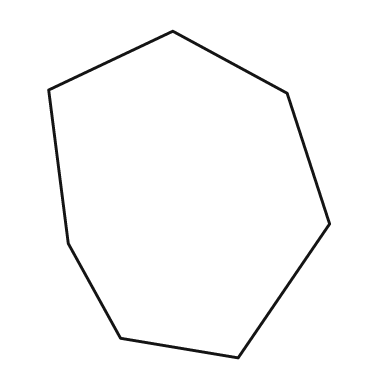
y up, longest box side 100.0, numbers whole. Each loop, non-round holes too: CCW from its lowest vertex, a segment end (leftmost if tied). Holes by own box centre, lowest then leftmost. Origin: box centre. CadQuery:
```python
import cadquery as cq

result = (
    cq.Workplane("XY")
    .moveTo(15.0, -50.0)
    .lineTo(43.0, -9.0)
    .lineTo(30.0, 31.0)
    .lineTo(-5.0, 50.0)
    .lineTo(-43.0, 32.0)
    .lineTo(-37.0, -15.0)
    .lineTo(-21.0, -44.0)
    .close()
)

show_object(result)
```